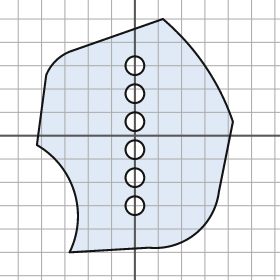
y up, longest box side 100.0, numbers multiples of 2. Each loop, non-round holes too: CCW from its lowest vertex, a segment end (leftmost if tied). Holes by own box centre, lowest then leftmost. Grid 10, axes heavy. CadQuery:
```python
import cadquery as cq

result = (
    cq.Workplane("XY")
    .moveTo(-28.0, -50.0)
    .lineTo(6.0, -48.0)
    .threePointArc((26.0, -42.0), (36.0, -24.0))
    .lineTo(42.0, 6.0)
    .threePointArc((30.0, 30.0), (12.0, 50.0))
    .lineTo(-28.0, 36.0)
    .threePointArc((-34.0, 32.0), (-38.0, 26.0))
    .lineTo(-42.0, -4.0)
    .threePointArc((-26.0, -24.0), (-28.0, -50.0))
    .close()
    .moveTo(0.0, -30.0)
    .circle(4.0)
    .moveTo(0.0, -18.0)
    .circle(4.0)
    .moveTo(0.0, -6.0)
    .circle(4.0)
    .moveTo(0.0, 6.0)
    .circle(4.0)
    .moveTo(0.0, 18.0)
    .circle(4.0)
    .moveTo(0.0, 30.0)
    .circle(4.0)
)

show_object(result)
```